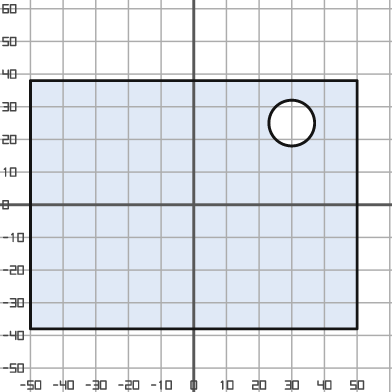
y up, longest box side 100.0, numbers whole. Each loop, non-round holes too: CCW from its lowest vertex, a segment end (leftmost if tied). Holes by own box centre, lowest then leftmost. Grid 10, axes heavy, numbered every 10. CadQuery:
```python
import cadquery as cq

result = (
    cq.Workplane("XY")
    .moveTo(-50.0, -38.0)
    .lineTo(50.0, -38.0)
    .lineTo(50.0, 38.0)
    .lineTo(-50.0, 38.0)
    .close()
    .moveTo(30.0, 25.0)
    .circle(7.0)
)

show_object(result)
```